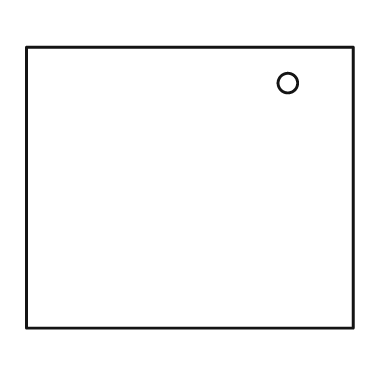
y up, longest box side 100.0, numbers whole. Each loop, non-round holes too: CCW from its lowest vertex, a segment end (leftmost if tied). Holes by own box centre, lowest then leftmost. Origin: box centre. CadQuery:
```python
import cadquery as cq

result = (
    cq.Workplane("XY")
    .moveTo(-50.0, -43.0)
    .lineTo(50.0, -43.0)
    .lineTo(50.0, 43.0)
    .lineTo(-50.0, 43.0)
    .close()
    .moveTo(30.0, 32.0)
    .circle(3.0)
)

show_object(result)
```